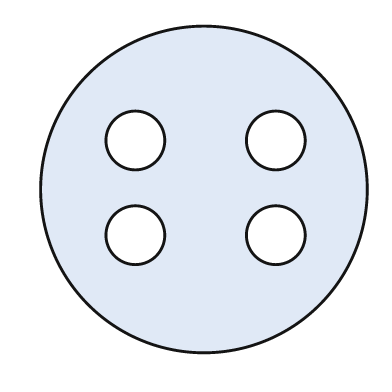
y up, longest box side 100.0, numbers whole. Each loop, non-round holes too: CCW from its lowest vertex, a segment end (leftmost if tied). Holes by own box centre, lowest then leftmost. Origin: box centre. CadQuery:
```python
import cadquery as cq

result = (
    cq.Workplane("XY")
    .moveTo(0.0, 0.0)
    .circle(50.0)
    .moveTo(-21.0, -14.0)
    .circle(9.0)
    .moveTo(22.0, -14.0)
    .circle(9.0)
    .moveTo(-21.0, 15.0)
    .circle(9.0)
    .moveTo(22.0, 15.0)
    .circle(9.0)
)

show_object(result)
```